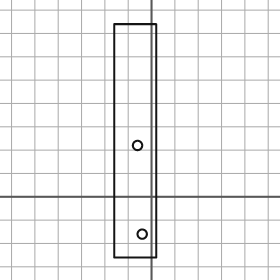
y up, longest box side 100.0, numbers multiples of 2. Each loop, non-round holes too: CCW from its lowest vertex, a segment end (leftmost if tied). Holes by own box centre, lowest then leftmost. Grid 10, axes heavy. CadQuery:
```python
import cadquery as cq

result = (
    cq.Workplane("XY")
    .moveTo(-16.0, -26.0)
    .lineTo(2.0, -26.0)
    .lineTo(2.0, 74.0)
    .lineTo(-16.0, 74.0)
    .close()
    .moveTo(-4.0, -16.0)
    .circle(2.0)
    .moveTo(-6.0, 22.0)
    .circle(2.0)
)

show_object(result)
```